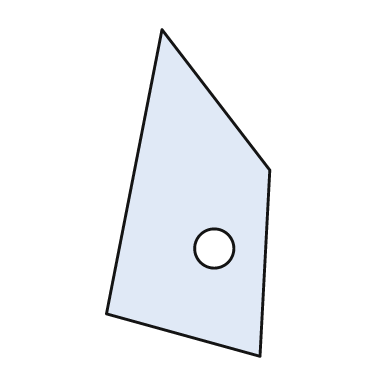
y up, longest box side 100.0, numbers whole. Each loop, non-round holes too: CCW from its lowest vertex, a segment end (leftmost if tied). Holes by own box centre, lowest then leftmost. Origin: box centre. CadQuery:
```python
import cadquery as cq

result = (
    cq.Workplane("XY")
    .moveTo(22.0, -50.0)
    .lineTo(25.0, 7.0)
    .lineTo(-8.0, 50.0)
    .lineTo(-25.0, -37.0)
    .close()
    .moveTo(8.0, -17.0)
    .circle(6.0)
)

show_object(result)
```